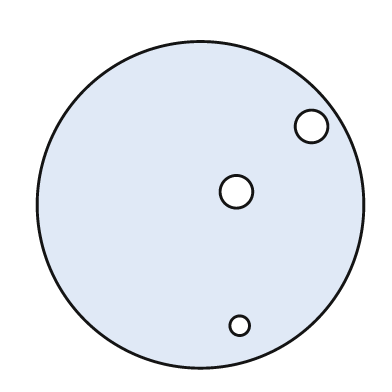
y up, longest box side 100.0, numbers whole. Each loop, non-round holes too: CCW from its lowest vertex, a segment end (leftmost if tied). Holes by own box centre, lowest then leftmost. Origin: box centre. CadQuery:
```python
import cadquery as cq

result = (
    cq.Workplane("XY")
    .moveTo(0.0, 0.0)
    .circle(50.0)
    .moveTo(12.0, -37.0)
    .circle(3.0)
    .moveTo(11.0, 4.0)
    .circle(5.0)
    .moveTo(34.0, 24.0)
    .circle(5.0)
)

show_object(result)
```